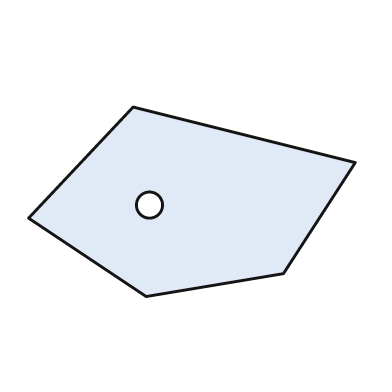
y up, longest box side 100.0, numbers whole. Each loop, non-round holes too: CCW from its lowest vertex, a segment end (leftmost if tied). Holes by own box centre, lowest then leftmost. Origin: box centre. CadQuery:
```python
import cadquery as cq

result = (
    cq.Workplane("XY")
    .moveTo(-14.0, -29.0)
    .lineTo(28.0, -22.0)
    .lineTo(50.0, 12.0)
    .lineTo(-18.0, 29.0)
    .lineTo(-50.0, -5.0)
    .close()
    .moveTo(-13.0, -1.0)
    .circle(4.0)
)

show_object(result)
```